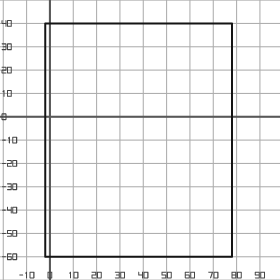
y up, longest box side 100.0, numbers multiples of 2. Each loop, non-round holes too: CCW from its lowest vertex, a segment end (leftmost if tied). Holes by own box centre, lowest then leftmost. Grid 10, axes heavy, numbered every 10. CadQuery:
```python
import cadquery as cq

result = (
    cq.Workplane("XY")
    .moveTo(-2.0, -60.0)
    .lineTo(78.0, -60.0)
    .lineTo(78.0, 40.0)
    .lineTo(-2.0, 40.0)
    .close()
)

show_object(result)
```